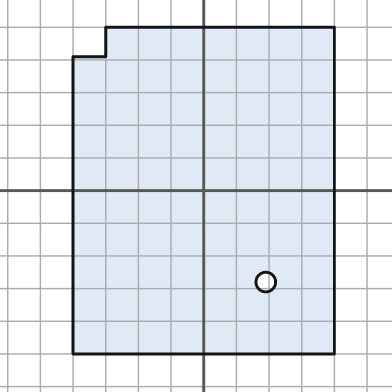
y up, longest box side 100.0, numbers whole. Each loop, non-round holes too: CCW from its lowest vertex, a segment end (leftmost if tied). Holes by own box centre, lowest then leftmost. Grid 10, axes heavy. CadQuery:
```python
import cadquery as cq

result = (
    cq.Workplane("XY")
    .moveTo(-40.0, -50.0)
    .lineTo(40.0, -50.0)
    .lineTo(40.0, 50.0)
    .lineTo(-30.0, 50.0)
    .lineTo(-30.0, 41.0)
    .lineTo(-40.0, 41.0)
    .close()
    .moveTo(19.0, -28.0)
    .circle(3.0)
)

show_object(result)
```